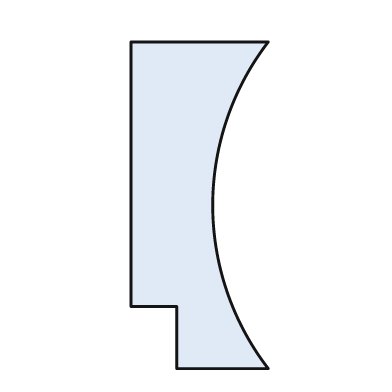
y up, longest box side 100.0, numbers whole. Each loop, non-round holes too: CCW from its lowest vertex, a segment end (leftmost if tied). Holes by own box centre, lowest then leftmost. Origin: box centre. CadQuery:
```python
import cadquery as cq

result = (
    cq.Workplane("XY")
    .moveTo(-7.0, -50.0)
    .lineTo(21.0, -50.0)
    .threePointArc((4.0, 0.0), (21.0, 50.0))
    .lineTo(-21.0, 50.0)
    .lineTo(-21.0, -31.0)
    .lineTo(-7.0, -31.0)
    .close()
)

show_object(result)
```